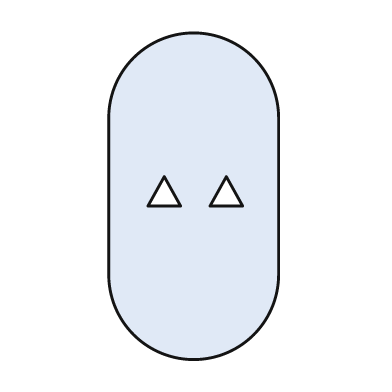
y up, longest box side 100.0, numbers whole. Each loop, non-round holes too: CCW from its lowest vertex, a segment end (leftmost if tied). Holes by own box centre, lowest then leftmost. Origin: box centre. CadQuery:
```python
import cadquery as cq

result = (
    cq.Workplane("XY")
    .moveTo(-26.0, -24.0)
    .threePointArc((0.0, -50.0), (26.0, -24.0))
    .lineTo(26.0, 24.0)
    .threePointArc((0.0, 50.0), (-26.0, 24.0))
    .close()
    .moveTo(-14.0, -3.0)
    .lineTo(-4.0, -3.0)
    .lineTo(-9.0, 6.0)
    .close()
    .moveTo(5.0, -3.0)
    .lineTo(15.0, -3.0)
    .lineTo(10.0, 6.0)
    .close()
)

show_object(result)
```